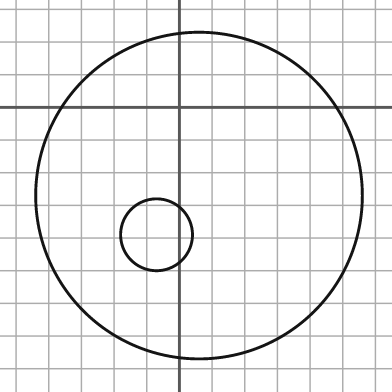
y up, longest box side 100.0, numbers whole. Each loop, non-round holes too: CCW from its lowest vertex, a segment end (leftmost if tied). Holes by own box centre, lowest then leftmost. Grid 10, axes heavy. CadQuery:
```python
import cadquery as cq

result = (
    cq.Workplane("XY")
    .moveTo(6.0, -27.0)
    .circle(50.0)
    .moveTo(-7.0, -39.0)
    .circle(11.0)
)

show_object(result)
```